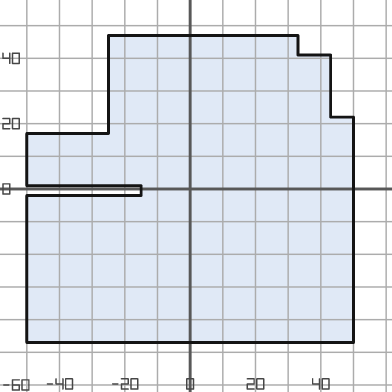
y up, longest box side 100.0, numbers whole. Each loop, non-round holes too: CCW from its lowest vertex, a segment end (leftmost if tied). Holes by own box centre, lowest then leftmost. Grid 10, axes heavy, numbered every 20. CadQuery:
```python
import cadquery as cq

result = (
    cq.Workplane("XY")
    .moveTo(-50.0, -47.0)
    .lineTo(50.0, -47.0)
    .lineTo(50.0, 22.0)
    .lineTo(43.0, 22.0)
    .lineTo(43.0, 41.0)
    .lineTo(33.0, 41.0)
    .lineTo(33.0, 47.0)
    .lineTo(-25.0, 47.0)
    .lineTo(-25.0, 17.0)
    .lineTo(-50.0, 17.0)
    .lineTo(-50.0, 1.0)
    .lineTo(-15.0, 1.0)
    .lineTo(-15.0, -2.0)
    .lineTo(-50.0, -2.0)
    .close()
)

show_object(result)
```